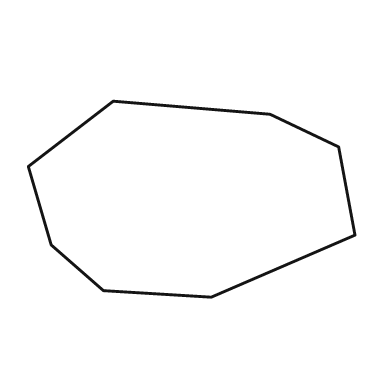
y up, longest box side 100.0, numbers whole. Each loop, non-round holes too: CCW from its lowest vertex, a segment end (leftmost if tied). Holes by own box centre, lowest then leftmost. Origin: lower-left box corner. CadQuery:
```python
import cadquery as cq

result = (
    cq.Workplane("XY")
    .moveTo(56.0, 0.0)
    .lineTo(100.0, 19.0)
    .lineTo(95.0, 46.0)
    .lineTo(74.0, 56.0)
    .lineTo(26.0, 60.0)
    .lineTo(0.0, 40.0)
    .lineTo(7.0, 16.0)
    .lineTo(23.0, 2.0)
    .close()
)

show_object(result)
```